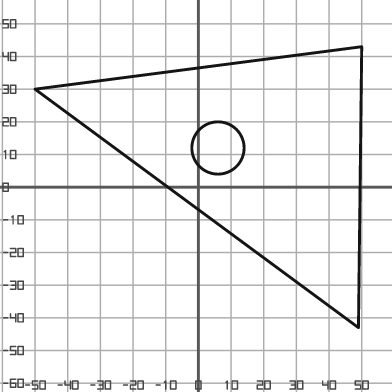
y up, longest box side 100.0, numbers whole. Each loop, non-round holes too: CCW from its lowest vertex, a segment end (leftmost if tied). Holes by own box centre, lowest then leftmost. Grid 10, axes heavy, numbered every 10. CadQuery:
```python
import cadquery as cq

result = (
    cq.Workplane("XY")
    .moveTo(49.0, -43.0)
    .lineTo(50.0, 43.0)
    .lineTo(-50.0, 30.0)
    .close()
    .moveTo(6.0, 12.0)
    .circle(8.0)
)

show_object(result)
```